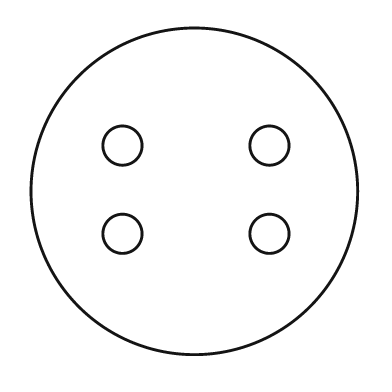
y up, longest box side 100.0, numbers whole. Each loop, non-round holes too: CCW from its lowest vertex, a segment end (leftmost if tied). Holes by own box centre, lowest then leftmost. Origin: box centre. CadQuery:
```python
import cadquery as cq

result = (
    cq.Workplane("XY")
    .moveTo(0.0, 0.0)
    .circle(50.0)
    .moveTo(-22.0, -13.0)
    .circle(6.0)
    .moveTo(23.0, -13.0)
    .circle(6.0)
    .moveTo(-22.0, 14.0)
    .circle(6.0)
    .moveTo(23.0, 14.0)
    .circle(6.0)
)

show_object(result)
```